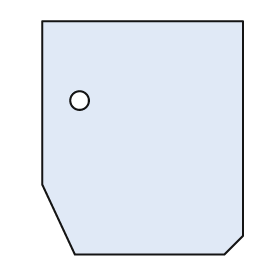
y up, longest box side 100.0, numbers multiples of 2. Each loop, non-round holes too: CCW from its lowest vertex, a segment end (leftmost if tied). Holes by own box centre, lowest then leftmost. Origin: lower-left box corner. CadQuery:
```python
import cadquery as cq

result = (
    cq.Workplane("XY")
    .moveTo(14.0, 0.0)
    .lineTo(78.0, 0.0)
    .lineTo(86.0, 8.0)
    .lineTo(86.0, 100.0)
    .lineTo(0.0, 100.0)
    .lineTo(0.0, 30.0)
    .close()
    .moveTo(16.0, 66.0)
    .circle(4.0)
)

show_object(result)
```